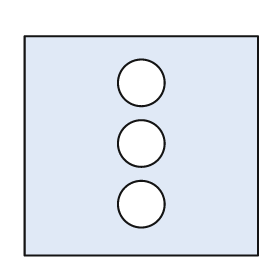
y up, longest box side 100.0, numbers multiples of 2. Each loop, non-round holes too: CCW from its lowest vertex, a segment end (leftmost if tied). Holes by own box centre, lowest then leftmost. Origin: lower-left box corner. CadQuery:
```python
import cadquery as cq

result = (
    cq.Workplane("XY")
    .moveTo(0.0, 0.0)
    .lineTo(100.0, 0.0)
    .lineTo(100.0, 94.0)
    .lineTo(0.0, 94.0)
    .close()
    .moveTo(50.0, 22.0)
    .circle(10.0)
    .moveTo(50.0, 48.0)
    .circle(10.0)
    .moveTo(50.0, 74.0)
    .circle(10.0)
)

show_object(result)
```